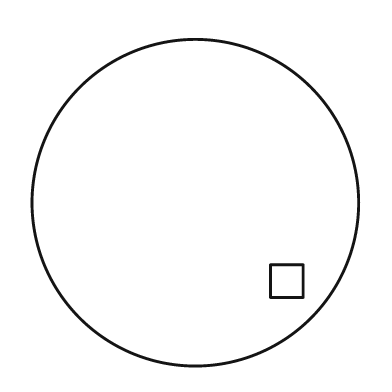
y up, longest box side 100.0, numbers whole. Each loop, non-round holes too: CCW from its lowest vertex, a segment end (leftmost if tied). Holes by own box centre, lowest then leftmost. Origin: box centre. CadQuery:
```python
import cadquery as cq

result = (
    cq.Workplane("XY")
    .moveTo(0.0, 0.0)
    .circle(50.0)
    .moveTo(23.0, -29.0)
    .lineTo(33.0, -29.0)
    .lineTo(33.0, -19.0)
    .lineTo(23.0, -19.0)
    .close()
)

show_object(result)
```